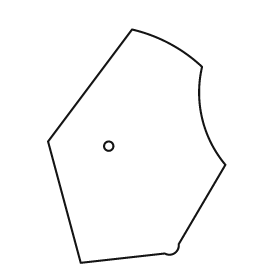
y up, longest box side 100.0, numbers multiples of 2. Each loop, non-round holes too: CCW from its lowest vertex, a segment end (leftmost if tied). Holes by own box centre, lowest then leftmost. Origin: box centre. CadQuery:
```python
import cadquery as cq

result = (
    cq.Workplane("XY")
    .moveTo(-24.0, -50.0)
    .lineTo(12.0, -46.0)
    .threePointArc((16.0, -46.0), (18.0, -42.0))
    .lineTo(38.0, -8.0)
    .threePointArc((28.0, 12.0), (28.0, 34.0))
    .threePointArc((14.0, 44.0), (-2.0, 50.0))
    .lineTo(-38.0, 2.0)
    .close()
    .moveTo(-12.0, 0.0)
    .circle(2.0)
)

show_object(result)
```